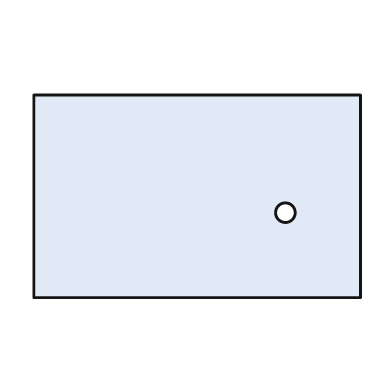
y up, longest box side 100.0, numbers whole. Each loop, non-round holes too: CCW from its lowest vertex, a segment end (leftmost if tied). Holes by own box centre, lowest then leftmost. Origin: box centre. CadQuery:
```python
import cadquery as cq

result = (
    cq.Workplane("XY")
    .moveTo(-50.0, -31.0)
    .lineTo(50.0, -31.0)
    .lineTo(50.0, 31.0)
    .lineTo(-50.0, 31.0)
    .close()
    .moveTo(27.0, -5.0)
    .circle(3.0)
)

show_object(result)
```